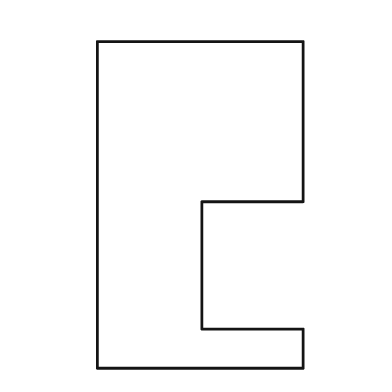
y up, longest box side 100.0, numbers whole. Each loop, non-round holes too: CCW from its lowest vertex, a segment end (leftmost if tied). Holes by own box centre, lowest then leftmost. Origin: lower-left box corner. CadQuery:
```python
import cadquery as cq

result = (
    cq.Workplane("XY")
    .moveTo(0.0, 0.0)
    .lineTo(63.0, 0.0)
    .lineTo(63.0, 12.0)
    .lineTo(32.0, 12.0)
    .lineTo(32.0, 51.0)
    .lineTo(63.0, 51.0)
    .lineTo(63.0, 100.0)
    .lineTo(0.0, 100.0)
    .close()
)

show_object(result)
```